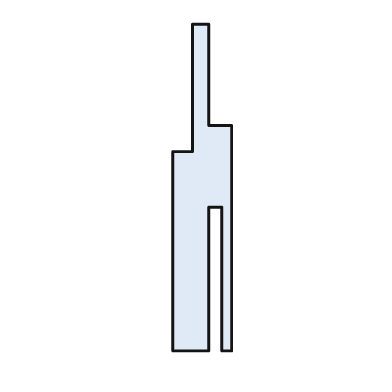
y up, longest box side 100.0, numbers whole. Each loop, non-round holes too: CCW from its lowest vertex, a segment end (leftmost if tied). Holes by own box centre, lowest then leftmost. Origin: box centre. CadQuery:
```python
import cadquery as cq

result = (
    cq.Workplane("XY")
    .moveTo(-9.0, -50.0)
    .lineTo(2.0, -50.0)
    .lineTo(2.0, -6.0)
    .lineTo(6.0, -6.0)
    .lineTo(6.0, -50.0)
    .lineTo(9.0, -50.0)
    .lineTo(9.0, 19.0)
    .lineTo(2.0, 19.0)
    .lineTo(2.0, 50.0)
    .lineTo(-3.0, 50.0)
    .lineTo(-3.0, 11.0)
    .lineTo(-9.0, 11.0)
    .close()
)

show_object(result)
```